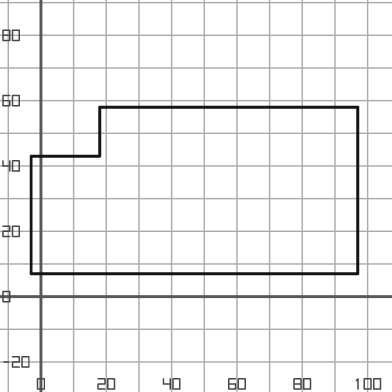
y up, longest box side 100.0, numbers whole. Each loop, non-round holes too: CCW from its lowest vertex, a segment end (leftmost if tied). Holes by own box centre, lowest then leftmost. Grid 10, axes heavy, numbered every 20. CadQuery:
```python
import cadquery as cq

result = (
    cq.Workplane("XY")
    .moveTo(-3.0, 7.0)
    .lineTo(97.0, 7.0)
    .lineTo(97.0, 58.0)
    .lineTo(18.0, 58.0)
    .lineTo(18.0, 43.0)
    .lineTo(-3.0, 43.0)
    .close()
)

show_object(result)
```